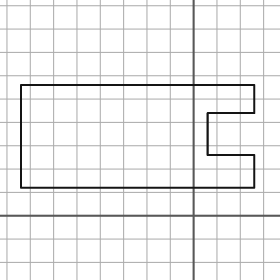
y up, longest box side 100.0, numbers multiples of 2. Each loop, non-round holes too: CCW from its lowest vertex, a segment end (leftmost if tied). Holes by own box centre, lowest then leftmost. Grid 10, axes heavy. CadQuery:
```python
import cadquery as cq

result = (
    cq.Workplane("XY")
    .moveTo(-74.0, 12.0)
    .lineTo(26.0, 12.0)
    .lineTo(26.0, 26.0)
    .lineTo(6.0, 26.0)
    .lineTo(6.0, 44.0)
    .lineTo(26.0, 44.0)
    .lineTo(26.0, 56.0)
    .lineTo(-74.0, 56.0)
    .close()
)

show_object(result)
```